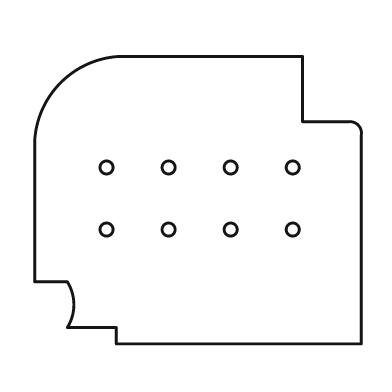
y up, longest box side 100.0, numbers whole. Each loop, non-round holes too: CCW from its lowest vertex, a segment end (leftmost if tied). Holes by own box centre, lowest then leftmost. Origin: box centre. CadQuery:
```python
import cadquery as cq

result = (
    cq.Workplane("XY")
    .moveTo(-25.0, -44.0)
    .lineTo(50.0, -44.0)
    .lineTo(50.0, 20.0)
    .threePointArc((49.0, 23.0), (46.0, 24.0))
    .lineTo(32.0, 24.0)
    .lineTo(32.0, 44.0)
    .lineTo(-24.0, 44.0)
    .threePointArc((-42.0, 36.0), (-50.0, 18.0))
    .lineTo(-50.0, -25.0)
    .lineTo(-40.0, -25.0)
    .threePointArc((-38.0, -32.0), (-40.0, -39.0))
    .lineTo(-25.0, -39.0)
    .close()
    .moveTo(-28.0, -9.0)
    .circle(2.0)
    .moveTo(-9.0, -9.0)
    .circle(2.0)
    .moveTo(10.0, -9.0)
    .circle(2.0)
    .moveTo(29.0, -9.0)
    .circle(2.0)
    .moveTo(-28.0, 10.0)
    .circle(2.0)
    .moveTo(-9.0, 10.0)
    .circle(2.0)
    .moveTo(10.0, 10.0)
    .circle(2.0)
    .moveTo(29.0, 10.0)
    .circle(2.0)
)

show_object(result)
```